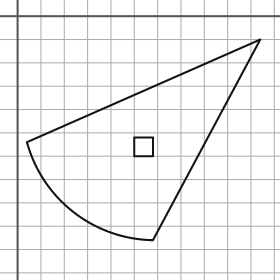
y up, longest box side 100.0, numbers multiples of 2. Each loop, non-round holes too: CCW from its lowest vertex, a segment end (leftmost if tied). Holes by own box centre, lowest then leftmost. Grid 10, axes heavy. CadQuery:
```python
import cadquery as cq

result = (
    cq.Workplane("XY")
    .moveTo(58.0, -96.0)
    .lineTo(104.0, -10.0)
    .lineTo(4.0, -54.0)
    .threePointArc((24.0, -84.0), (58.0, -96.0))
    .close()
    .moveTo(50.0, -60.0)
    .lineTo(58.0, -60.0)
    .lineTo(58.0, -52.0)
    .lineTo(50.0, -52.0)
    .close()
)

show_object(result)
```